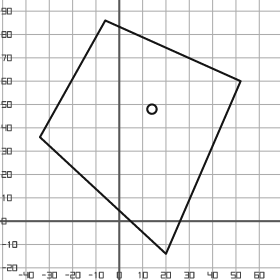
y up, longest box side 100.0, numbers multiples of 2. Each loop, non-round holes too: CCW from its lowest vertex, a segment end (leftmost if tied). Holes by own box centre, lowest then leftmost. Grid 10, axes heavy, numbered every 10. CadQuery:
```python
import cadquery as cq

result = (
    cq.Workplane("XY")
    .moveTo(20.0, -14.0)
    .lineTo(52.0, 60.0)
    .lineTo(-6.0, 86.0)
    .lineTo(-34.0, 36.0)
    .close()
    .moveTo(14.0, 48.0)
    .circle(2.0)
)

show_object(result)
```